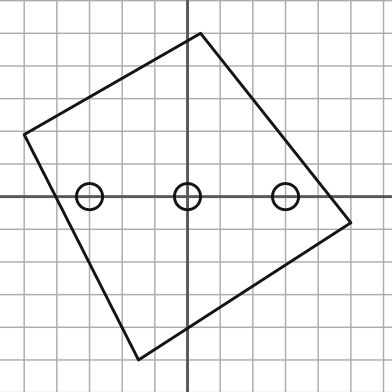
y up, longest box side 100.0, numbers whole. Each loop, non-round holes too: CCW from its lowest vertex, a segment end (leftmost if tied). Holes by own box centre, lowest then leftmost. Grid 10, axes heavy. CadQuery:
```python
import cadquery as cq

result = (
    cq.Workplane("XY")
    .moveTo(-15.0, -50.0)
    .lineTo(50.0, -8.0)
    .lineTo(4.0, 50.0)
    .lineTo(-50.0, 19.0)
    .close()
    .moveTo(-30.0, 0.0)
    .circle(4.0)
    .moveTo(0.0, 0.0)
    .circle(4.0)
    .moveTo(30.0, 0.0)
    .circle(4.0)
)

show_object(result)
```